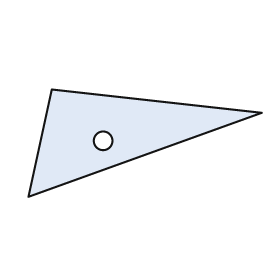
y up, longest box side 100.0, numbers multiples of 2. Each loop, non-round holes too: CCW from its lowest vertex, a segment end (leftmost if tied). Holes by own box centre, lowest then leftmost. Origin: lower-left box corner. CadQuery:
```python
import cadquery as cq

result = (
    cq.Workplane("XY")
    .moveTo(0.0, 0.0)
    .lineTo(100.0, 36.0)
    .lineTo(10.0, 46.0)
    .close()
    .moveTo(32.0, 24.0)
    .circle(4.0)
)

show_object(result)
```